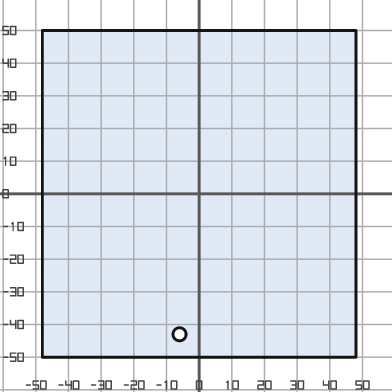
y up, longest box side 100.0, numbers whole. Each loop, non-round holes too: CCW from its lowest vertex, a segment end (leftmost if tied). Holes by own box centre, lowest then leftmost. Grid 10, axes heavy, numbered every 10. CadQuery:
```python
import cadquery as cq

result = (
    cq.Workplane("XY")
    .moveTo(-48.0, -50.0)
    .lineTo(48.0, -50.0)
    .lineTo(48.0, 50.0)
    .lineTo(-48.0, 50.0)
    .close()
    .moveTo(-6.0, -43.0)
    .circle(2.0)
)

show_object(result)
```